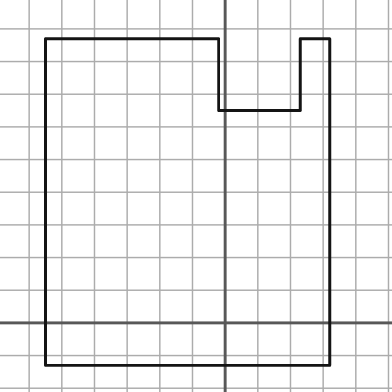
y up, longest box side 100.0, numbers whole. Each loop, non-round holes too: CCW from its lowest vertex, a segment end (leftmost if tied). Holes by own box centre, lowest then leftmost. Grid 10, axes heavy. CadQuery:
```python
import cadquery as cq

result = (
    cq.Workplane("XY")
    .moveTo(-55.0, -13.0)
    .lineTo(32.0, -13.0)
    .lineTo(32.0, 87.0)
    .lineTo(23.0, 87.0)
    .lineTo(23.0, 65.0)
    .lineTo(-2.0, 65.0)
    .lineTo(-2.0, 87.0)
    .lineTo(-55.0, 87.0)
    .close()
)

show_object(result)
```